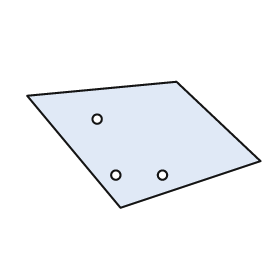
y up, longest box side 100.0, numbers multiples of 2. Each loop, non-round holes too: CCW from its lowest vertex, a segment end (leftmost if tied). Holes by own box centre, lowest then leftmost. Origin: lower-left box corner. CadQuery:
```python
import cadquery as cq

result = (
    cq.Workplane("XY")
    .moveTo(40.0, 0.0)
    .lineTo(100.0, 20.0)
    .lineTo(64.0, 54.0)
    .lineTo(0.0, 48.0)
    .close()
    .moveTo(38.0, 14.0)
    .circle(2.0)
    .moveTo(58.0, 14.0)
    .circle(2.0)
    .moveTo(30.0, 38.0)
    .circle(2.0)
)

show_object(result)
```